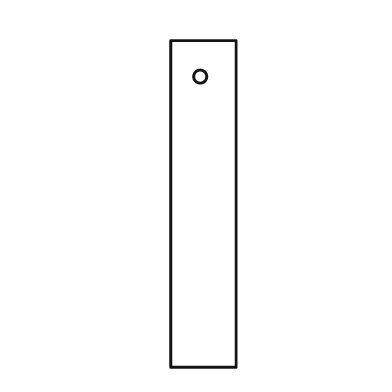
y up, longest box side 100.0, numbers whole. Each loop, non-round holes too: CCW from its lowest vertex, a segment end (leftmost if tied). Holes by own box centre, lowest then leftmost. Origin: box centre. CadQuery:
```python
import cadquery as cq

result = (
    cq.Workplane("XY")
    .moveTo(-10.0, -50.0)
    .lineTo(10.0, -50.0)
    .lineTo(10.0, 50.0)
    .lineTo(-10.0, 50.0)
    .close()
    .moveTo(-1.0, 39.0)
    .circle(2.0)
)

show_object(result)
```